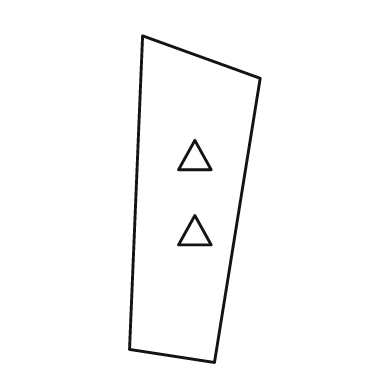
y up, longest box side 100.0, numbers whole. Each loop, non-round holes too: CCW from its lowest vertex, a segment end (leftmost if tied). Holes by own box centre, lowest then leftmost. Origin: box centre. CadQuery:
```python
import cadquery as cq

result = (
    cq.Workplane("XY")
    .moveTo(6.0, -50.0)
    .lineTo(20.0, 37.0)
    .lineTo(-16.0, 50.0)
    .lineTo(-20.0, -46.0)
    .close()
    .moveTo(-5.0, -14.0)
    .lineTo(5.0, -14.0)
    .lineTo(0.0, -5.0)
    .close()
    .moveTo(-5.0, 9.0)
    .lineTo(5.0, 9.0)
    .lineTo(0.0, 18.0)
    .close()
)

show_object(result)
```